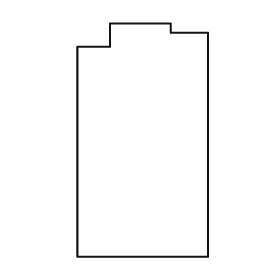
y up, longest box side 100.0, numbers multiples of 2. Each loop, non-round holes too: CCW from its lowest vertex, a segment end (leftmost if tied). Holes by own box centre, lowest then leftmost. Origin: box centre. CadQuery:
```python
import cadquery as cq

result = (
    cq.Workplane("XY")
    .moveTo(-28.0, -50.0)
    .lineTo(28.0, -50.0)
    .lineTo(28.0, 46.0)
    .lineTo(12.0, 46.0)
    .lineTo(12.0, 50.0)
    .lineTo(-14.0, 50.0)
    .lineTo(-14.0, 40.0)
    .lineTo(-28.0, 40.0)
    .close()
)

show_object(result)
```